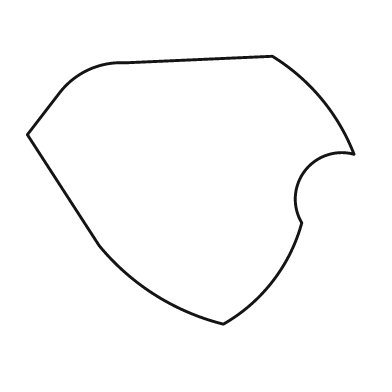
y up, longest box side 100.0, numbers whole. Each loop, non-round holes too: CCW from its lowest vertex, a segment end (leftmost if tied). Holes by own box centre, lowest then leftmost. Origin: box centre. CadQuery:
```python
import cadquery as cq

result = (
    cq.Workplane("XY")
    .moveTo(10.0, -41.0)
    .threePointArc((25.0, -28.0), (34.0, -10.0))
    .threePointArc((35.0, 6.0), (50.0, 11.0))
    .threePointArc((40.0, 28.0), (25.0, 41.0))
    .lineTo(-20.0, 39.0)
    .threePointArc((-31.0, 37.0), (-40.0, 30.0))
    .lineTo(-50.0, 17.0)
    .lineTo(-28.0, -17.0)
    .threePointArc((-11.0, -32.0), (10.0, -41.0))
    .close()
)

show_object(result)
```